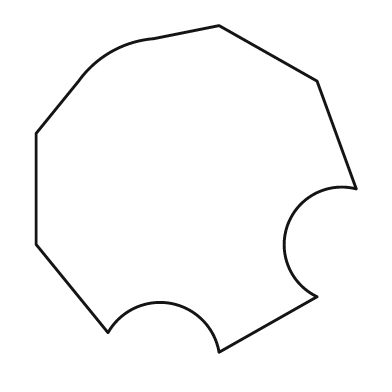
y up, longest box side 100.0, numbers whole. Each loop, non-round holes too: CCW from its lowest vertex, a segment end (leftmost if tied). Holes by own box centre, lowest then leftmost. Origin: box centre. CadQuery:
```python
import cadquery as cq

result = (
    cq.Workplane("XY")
    .moveTo(7.0, -50.0)
    .lineTo(37.0, -33.0)
    .threePointArc((28.0, -11.0), (49.0, 0.0))
    .lineTo(37.0, 33.0)
    .lineTo(7.0, 50.0)
    .lineTo(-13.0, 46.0)
    .threePointArc((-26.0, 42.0), (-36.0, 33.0))
    .lineTo(-49.0, 17.0)
    .lineTo(-49.0, -17.0)
    .lineTo(-27.0, -44.0)
    .threePointArc((-8.0, -35.0), (7.0, -50.0))
    .close()
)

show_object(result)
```